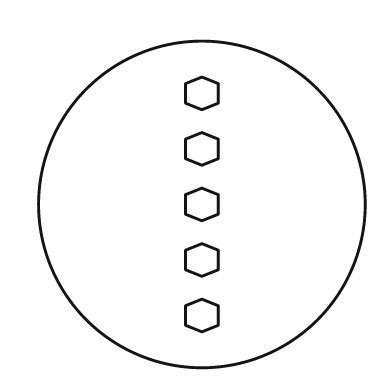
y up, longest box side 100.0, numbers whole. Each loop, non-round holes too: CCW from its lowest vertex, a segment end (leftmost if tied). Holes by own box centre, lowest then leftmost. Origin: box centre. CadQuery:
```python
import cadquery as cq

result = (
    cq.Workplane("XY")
    .moveTo(0.0, 0.0)
    .circle(50.0)
    .moveTo(0.0, -39.0)
    .lineTo(5.0, -37.0)
    .lineTo(5.0, -31.0)
    .lineTo(0.0, -29.0)
    .lineTo(-5.0, -31.0)
    .lineTo(-5.0, -37.0)
    .close()
    .moveTo(0.0, -22.0)
    .lineTo(5.0, -20.0)
    .lineTo(5.0, -14.0)
    .lineTo(0.0, -12.0)
    .lineTo(-5.0, -14.0)
    .lineTo(-5.0, -20.0)
    .close()
    .moveTo(0.0, -5.0)
    .lineTo(5.0, -3.0)
    .lineTo(5.0, 3.0)
    .lineTo(0.0, 5.0)
    .lineTo(-5.0, 3.0)
    .lineTo(-5.0, -3.0)
    .close()
    .moveTo(0.0, 12.0)
    .lineTo(5.0, 14.0)
    .lineTo(5.0, 20.0)
    .lineTo(0.0, 22.0)
    .lineTo(-5.0, 20.0)
    .lineTo(-5.0, 14.0)
    .close()
    .moveTo(0.0, 29.0)
    .lineTo(5.0, 31.0)
    .lineTo(5.0, 37.0)
    .lineTo(0.0, 39.0)
    .lineTo(-5.0, 37.0)
    .lineTo(-5.0, 31.0)
    .close()
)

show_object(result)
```